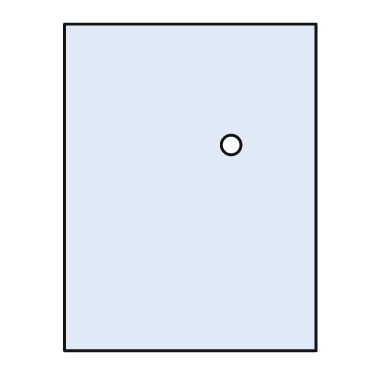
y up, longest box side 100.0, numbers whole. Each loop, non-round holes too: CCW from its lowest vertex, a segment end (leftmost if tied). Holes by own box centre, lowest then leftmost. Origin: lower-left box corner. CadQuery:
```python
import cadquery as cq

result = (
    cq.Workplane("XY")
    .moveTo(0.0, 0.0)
    .lineTo(77.0, 0.0)
    .lineTo(77.0, 100.0)
    .lineTo(0.0, 100.0)
    .close()
    .moveTo(51.0, 63.0)
    .circle(3.0)
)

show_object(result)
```